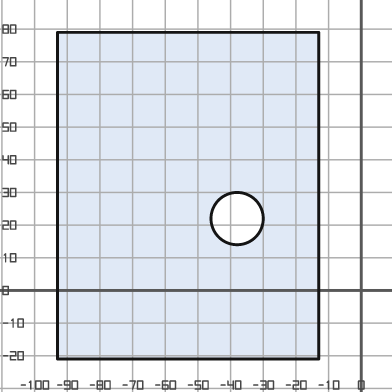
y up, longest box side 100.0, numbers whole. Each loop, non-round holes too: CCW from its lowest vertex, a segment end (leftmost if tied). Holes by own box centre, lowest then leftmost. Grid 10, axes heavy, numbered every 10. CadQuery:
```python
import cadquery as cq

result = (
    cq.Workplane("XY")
    .moveTo(-93.0, -21.0)
    .lineTo(-13.0, -21.0)
    .lineTo(-13.0, 79.0)
    .lineTo(-93.0, 79.0)
    .close()
    .moveTo(-38.0, 22.0)
    .circle(8.0)
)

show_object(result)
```